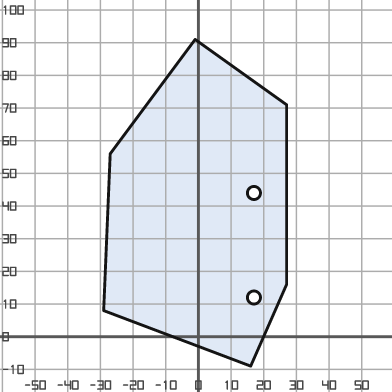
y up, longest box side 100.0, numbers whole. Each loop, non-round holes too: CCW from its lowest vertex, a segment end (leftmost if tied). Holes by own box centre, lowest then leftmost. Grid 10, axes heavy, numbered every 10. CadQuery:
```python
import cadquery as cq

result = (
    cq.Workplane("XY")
    .moveTo(16.0, -9.0)
    .lineTo(27.0, 16.0)
    .lineTo(27.0, 71.0)
    .lineTo(-1.0, 91.0)
    .lineTo(-27.0, 56.0)
    .lineTo(-29.0, 8.0)
    .close()
    .moveTo(17.0, 12.0)
    .circle(2.0)
    .moveTo(17.0, 44.0)
    .circle(2.0)
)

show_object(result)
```